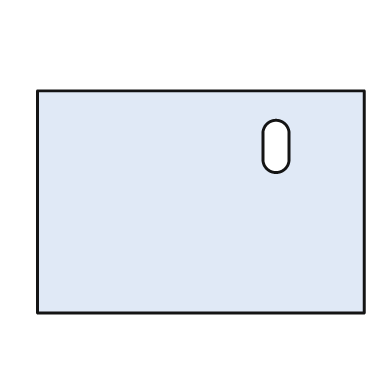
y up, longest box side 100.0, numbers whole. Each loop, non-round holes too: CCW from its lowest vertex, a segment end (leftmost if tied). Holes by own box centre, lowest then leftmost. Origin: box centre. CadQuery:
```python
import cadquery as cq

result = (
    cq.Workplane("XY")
    .moveTo(-50.0, -34.0)
    .lineTo(50.0, -34.0)
    .lineTo(50.0, 34.0)
    .lineTo(-50.0, 34.0)
    .close()
    .moveTo(19.0, 13.0)
    .threePointArc((23.0, 9.0), (27.0, 13.0))
    .lineTo(27.0, 21.0)
    .threePointArc((23.0, 25.0), (19.0, 21.0))
    .close()
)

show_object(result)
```